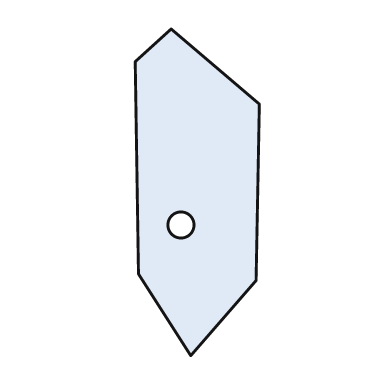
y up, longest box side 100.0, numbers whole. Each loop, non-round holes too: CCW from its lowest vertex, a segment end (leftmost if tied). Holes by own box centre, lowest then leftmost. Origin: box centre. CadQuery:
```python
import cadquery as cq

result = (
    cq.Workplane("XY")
    .moveTo(-2.0, -50.0)
    .lineTo(18.0, -27.0)
    .lineTo(19.0, 27.0)
    .lineTo(-8.0, 50.0)
    .lineTo(-19.0, 40.0)
    .lineTo(-18.0, -25.0)
    .close()
    .moveTo(-5.0, -10.0)
    .circle(4.0)
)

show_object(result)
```